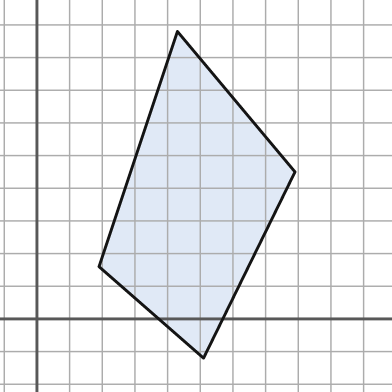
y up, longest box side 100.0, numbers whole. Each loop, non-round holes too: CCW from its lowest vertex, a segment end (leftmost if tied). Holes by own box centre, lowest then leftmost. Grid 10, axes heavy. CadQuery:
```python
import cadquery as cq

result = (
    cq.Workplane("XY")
    .moveTo(51.0, -12.0)
    .lineTo(79.0, 45.0)
    .lineTo(43.0, 88.0)
    .lineTo(19.0, 16.0)
    .close()
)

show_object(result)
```